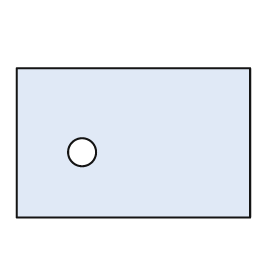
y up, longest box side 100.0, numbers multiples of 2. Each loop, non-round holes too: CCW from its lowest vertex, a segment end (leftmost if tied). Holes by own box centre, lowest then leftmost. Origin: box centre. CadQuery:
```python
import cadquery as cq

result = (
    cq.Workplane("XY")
    .moveTo(-50.0, -32.0)
    .lineTo(50.0, -32.0)
    .lineTo(50.0, 32.0)
    .lineTo(-50.0, 32.0)
    .close()
    .moveTo(-22.0, -4.0)
    .circle(6.0)
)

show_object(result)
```